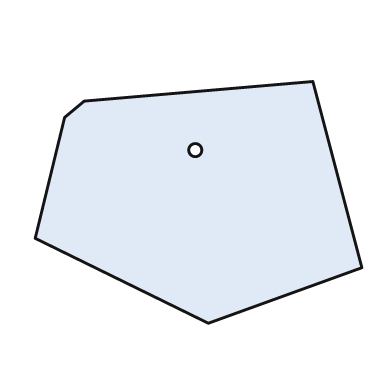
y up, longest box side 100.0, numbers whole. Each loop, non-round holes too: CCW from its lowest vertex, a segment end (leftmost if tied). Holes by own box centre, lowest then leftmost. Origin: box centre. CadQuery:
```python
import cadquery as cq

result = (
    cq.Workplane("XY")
    .moveTo(3.0, -37.0)
    .lineTo(50.0, -20.0)
    .lineTo(35.0, 37.0)
    .lineTo(-35.0, 31.0)
    .lineTo(-41.0, 26.0)
    .lineTo(-50.0, -11.0)
    .close()
    .moveTo(-1.0, 16.0)
    .circle(2.0)
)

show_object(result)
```